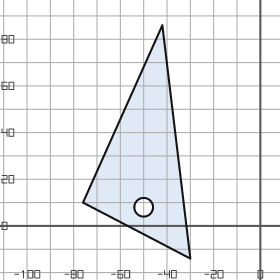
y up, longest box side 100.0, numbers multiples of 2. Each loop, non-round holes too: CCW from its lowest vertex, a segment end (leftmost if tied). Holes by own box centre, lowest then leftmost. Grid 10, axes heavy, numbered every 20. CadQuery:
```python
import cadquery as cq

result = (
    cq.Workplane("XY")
    .moveTo(-30.0, -14.0)
    .lineTo(-42.0, 86.0)
    .lineTo(-76.0, 10.0)
    .close()
    .moveTo(-50.0, 8.0)
    .circle(4.0)
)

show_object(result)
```